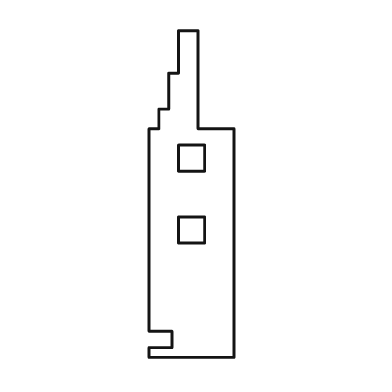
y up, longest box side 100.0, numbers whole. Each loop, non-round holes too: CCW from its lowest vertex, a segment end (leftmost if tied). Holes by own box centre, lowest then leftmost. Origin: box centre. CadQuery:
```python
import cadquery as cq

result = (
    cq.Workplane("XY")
    .moveTo(-13.0, -50.0)
    .lineTo(13.0, -50.0)
    .lineTo(13.0, 20.0)
    .lineTo(2.0, 20.0)
    .lineTo(2.0, 50.0)
    .lineTo(-4.0, 50.0)
    .lineTo(-4.0, 37.0)
    .lineTo(-7.0, 37.0)
    .lineTo(-7.0, 26.0)
    .lineTo(-10.0, 26.0)
    .lineTo(-10.0, 20.0)
    .lineTo(-13.0, 20.0)
    .lineTo(-13.0, -42.0)
    .lineTo(-6.0, -42.0)
    .lineTo(-6.0, -47.0)
    .lineTo(-13.0, -47.0)
    .close()
    .moveTo(-4.0, -15.0)
    .lineTo(4.0, -15.0)
    .lineTo(4.0, -7.0)
    .lineTo(-4.0, -7.0)
    .close()
    .moveTo(-4.0, 7.0)
    .lineTo(4.0, 7.0)
    .lineTo(4.0, 15.0)
    .lineTo(-4.0, 15.0)
    .close()
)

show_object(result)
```